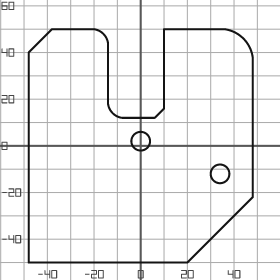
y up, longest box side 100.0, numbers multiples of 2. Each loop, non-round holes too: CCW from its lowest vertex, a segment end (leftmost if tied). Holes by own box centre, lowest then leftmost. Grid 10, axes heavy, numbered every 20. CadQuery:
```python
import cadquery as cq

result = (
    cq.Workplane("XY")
    .moveTo(-48.0, -50.0)
    .lineTo(20.0, -50.0)
    .lineTo(48.0, -22.0)
    .lineTo(48.0, 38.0)
    .threePointArc((44.0, 46.0), (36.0, 50.0))
    .lineTo(10.0, 50.0)
    .lineTo(10.0, 16.0)
    .lineTo(6.0, 12.0)
    .lineTo(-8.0, 12.0)
    .threePointArc((-12.0, 14.0), (-14.0, 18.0))
    .lineTo(-14.0, 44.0)
    .threePointArc((-16.0, 48.0), (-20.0, 50.0))
    .lineTo(-38.0, 50.0)
    .lineTo(-48.0, 40.0)
    .close()
    .moveTo(34.0, -12.0)
    .circle(4.0)
    .moveTo(0.0, 2.0)
    .circle(4.0)
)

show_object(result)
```